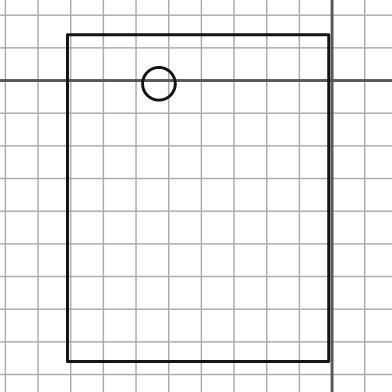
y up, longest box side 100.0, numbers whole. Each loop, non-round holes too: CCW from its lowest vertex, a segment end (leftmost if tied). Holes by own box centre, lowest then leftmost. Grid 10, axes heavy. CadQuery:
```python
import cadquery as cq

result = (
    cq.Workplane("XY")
    .moveTo(-81.0, -86.0)
    .lineTo(-1.0, -86.0)
    .lineTo(-1.0, 14.0)
    .lineTo(-81.0, 14.0)
    .close()
    .moveTo(-53.0, -1.0)
    .circle(5.0)
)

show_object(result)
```